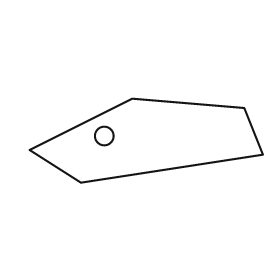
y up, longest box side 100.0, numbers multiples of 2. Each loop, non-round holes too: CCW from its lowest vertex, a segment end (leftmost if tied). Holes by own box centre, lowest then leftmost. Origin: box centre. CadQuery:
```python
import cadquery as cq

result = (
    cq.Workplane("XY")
    .moveTo(-28.0, -18.0)
    .lineTo(50.0, -6.0)
    .lineTo(42.0, 14.0)
    .lineTo(-6.0, 18.0)
    .lineTo(-50.0, -4.0)
    .close()
    .moveTo(-18.0, 2.0)
    .circle(4.0)
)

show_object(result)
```